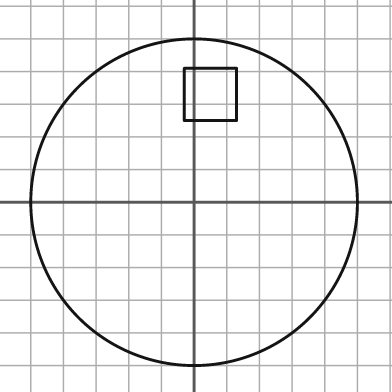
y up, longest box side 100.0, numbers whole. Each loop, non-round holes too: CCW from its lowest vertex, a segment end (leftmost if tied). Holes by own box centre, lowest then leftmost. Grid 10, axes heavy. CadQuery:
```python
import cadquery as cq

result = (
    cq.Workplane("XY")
    .moveTo(0.0, 0.0)
    .circle(50.0)
    .moveTo(-3.0, 25.0)
    .lineTo(13.0, 25.0)
    .lineTo(13.0, 41.0)
    .lineTo(-3.0, 41.0)
    .close()
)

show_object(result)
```